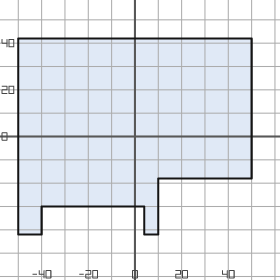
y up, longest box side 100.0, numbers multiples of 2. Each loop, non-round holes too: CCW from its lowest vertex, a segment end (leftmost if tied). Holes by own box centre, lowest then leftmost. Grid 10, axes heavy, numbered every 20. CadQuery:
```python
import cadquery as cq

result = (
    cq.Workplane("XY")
    .moveTo(-50.0, -42.0)
    .lineTo(-40.0, -42.0)
    .lineTo(-40.0, -30.0)
    .lineTo(4.0, -30.0)
    .lineTo(4.0, -42.0)
    .lineTo(10.0, -42.0)
    .lineTo(10.0, -18.0)
    .lineTo(50.0, -18.0)
    .lineTo(50.0, 42.0)
    .lineTo(-50.0, 42.0)
    .close()
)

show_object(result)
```